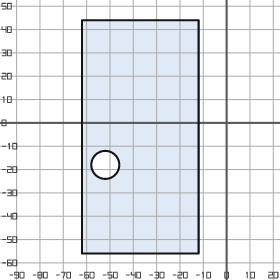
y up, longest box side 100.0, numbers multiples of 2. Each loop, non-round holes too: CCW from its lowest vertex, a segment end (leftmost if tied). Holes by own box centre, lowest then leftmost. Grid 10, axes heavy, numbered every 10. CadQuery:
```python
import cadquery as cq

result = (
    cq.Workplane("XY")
    .moveTo(-62.0, -56.0)
    .lineTo(-12.0, -56.0)
    .lineTo(-12.0, 44.0)
    .lineTo(-62.0, 44.0)
    .close()
    .moveTo(-52.0, -18.0)
    .circle(6.0)
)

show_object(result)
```